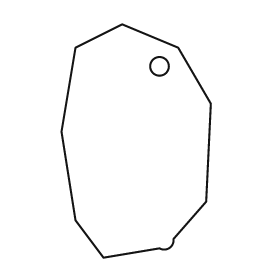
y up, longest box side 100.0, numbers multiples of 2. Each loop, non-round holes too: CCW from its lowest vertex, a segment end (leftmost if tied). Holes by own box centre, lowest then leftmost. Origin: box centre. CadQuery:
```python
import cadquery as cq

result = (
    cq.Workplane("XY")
    .moveTo(-14.0, -50.0)
    .lineTo(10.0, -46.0)
    .threePointArc((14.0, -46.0), (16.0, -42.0))
    .lineTo(30.0, -26.0)
    .lineTo(32.0, 16.0)
    .lineTo(18.0, 40.0)
    .lineTo(-6.0, 50.0)
    .lineTo(-26.0, 40.0)
    .lineTo(-32.0, 4.0)
    .lineTo(-26.0, -34.0)
    .close()
    .moveTo(10.0, 32.0)
    .circle(4.0)
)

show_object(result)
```